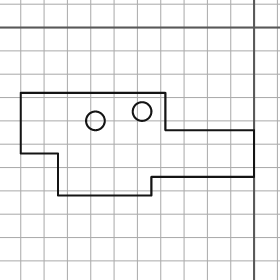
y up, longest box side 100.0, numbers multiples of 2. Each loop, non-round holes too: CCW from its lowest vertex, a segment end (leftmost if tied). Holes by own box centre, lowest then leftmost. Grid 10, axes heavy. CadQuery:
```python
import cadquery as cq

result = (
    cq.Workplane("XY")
    .moveTo(-84.0, -72.0)
    .lineTo(-44.0, -72.0)
    .lineTo(-44.0, -64.0)
    .lineTo(0.0, -64.0)
    .lineTo(0.0, -44.0)
    .lineTo(-38.0, -44.0)
    .lineTo(-38.0, -28.0)
    .lineTo(-100.0, -28.0)
    .lineTo(-100.0, -54.0)
    .lineTo(-84.0, -54.0)
    .close()
    .moveTo(-68.0, -40.0)
    .circle(4.0)
    .moveTo(-48.0, -36.0)
    .circle(4.0)
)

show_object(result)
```